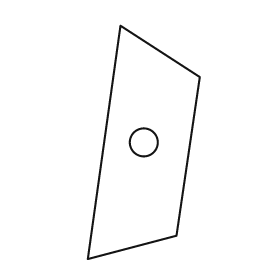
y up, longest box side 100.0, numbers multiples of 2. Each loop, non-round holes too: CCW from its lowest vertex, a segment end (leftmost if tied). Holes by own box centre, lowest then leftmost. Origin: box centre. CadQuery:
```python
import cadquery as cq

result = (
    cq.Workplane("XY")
    .moveTo(-24.0, -50.0)
    .lineTo(14.0, -40.0)
    .lineTo(24.0, 28.0)
    .lineTo(-10.0, 50.0)
    .close()
    .moveTo(0.0, 0.0)
    .circle(6.0)
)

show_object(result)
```